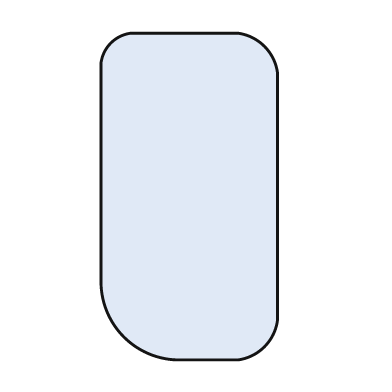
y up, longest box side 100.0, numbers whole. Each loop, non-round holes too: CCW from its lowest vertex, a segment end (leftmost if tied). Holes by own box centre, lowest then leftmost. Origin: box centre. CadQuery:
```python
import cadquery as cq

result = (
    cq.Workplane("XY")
    .moveTo(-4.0, -50.0)
    .lineTo(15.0, -50.0)
    .threePointArc((23.0, -46.0), (27.0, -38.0))
    .lineTo(27.0, 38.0)
    .threePointArc((23.0, 46.0), (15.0, 50.0))
    .lineTo(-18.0, 50.0)
    .threePointArc((-24.0, 47.0), (-27.0, 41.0))
    .lineTo(-27.0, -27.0)
    .threePointArc((-20.0, -43.0), (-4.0, -50.0))
    .close()
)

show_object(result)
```